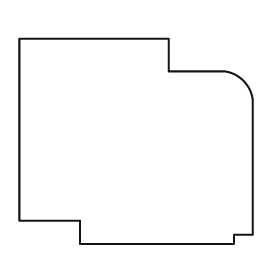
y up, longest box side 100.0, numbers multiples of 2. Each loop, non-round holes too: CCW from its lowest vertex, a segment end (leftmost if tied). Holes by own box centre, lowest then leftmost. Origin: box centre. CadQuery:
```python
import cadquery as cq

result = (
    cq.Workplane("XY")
    .moveTo(-24.0, -44.0)
    .lineTo(42.0, -44.0)
    .lineTo(42.0, -40.0)
    .lineTo(50.0, -40.0)
    .lineTo(50.0, 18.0)
    .threePointArc((46.0, 26.0), (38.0, 30.0))
    .lineTo(14.0, 30.0)
    .lineTo(14.0, 44.0)
    .lineTo(-50.0, 44.0)
    .lineTo(-50.0, -34.0)
    .lineTo(-24.0, -34.0)
    .close()
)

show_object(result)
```